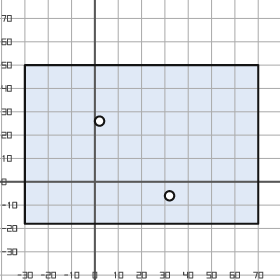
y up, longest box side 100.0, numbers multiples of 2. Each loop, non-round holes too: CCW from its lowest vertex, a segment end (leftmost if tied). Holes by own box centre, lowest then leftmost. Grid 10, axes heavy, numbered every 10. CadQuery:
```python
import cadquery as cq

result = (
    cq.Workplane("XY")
    .moveTo(-30.0, -18.0)
    .lineTo(70.0, -18.0)
    .lineTo(70.0, 50.0)
    .lineTo(-30.0, 50.0)
    .close()
    .moveTo(32.0, -6.0)
    .circle(2.0)
    .moveTo(2.0, 26.0)
    .circle(2.0)
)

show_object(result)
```